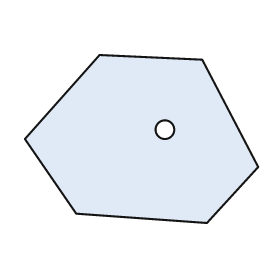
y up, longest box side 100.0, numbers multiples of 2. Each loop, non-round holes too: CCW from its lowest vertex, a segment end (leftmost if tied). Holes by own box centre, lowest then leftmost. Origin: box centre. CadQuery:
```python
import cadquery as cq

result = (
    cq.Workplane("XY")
    .moveTo(28.0, -36.0)
    .lineTo(50.0, -12.0)
    .lineTo(26.0, 34.0)
    .lineTo(-18.0, 36.0)
    .lineTo(-50.0, 0.0)
    .lineTo(-28.0, -32.0)
    .close()
    .moveTo(10.0, 4.0)
    .circle(4.0)
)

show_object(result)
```